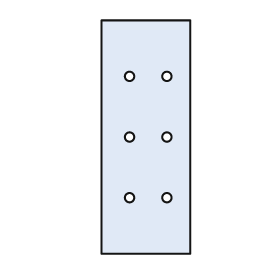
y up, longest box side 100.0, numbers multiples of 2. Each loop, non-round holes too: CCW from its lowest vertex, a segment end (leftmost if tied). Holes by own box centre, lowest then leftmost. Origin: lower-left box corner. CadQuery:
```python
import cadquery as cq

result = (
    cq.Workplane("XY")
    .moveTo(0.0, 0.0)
    .lineTo(38.0, 0.0)
    .lineTo(38.0, 100.0)
    .lineTo(0.0, 100.0)
    .close()
    .moveTo(12.0, 24.0)
    .circle(2.0)
    .moveTo(28.0, 24.0)
    .circle(2.0)
    .moveTo(12.0, 50.0)
    .circle(2.0)
    .moveTo(28.0, 50.0)
    .circle(2.0)
    .moveTo(12.0, 76.0)
    .circle(2.0)
    .moveTo(28.0, 76.0)
    .circle(2.0)
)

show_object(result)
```